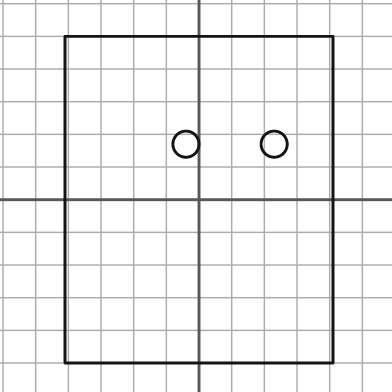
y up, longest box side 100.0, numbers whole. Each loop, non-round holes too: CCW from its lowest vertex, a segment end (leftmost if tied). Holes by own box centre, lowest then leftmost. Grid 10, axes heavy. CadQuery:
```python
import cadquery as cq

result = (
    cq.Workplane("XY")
    .moveTo(-41.0, -50.0)
    .lineTo(41.0, -50.0)
    .lineTo(41.0, 50.0)
    .lineTo(-41.0, 50.0)
    .close()
    .moveTo(-4.0, 17.0)
    .circle(4.0)
    .moveTo(23.0, 17.0)
    .circle(4.0)
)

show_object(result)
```